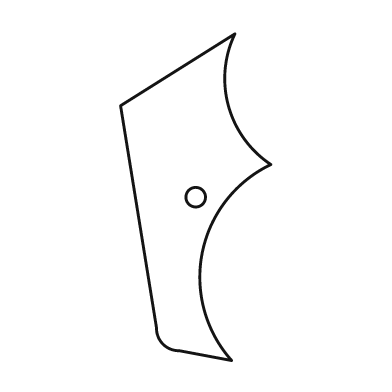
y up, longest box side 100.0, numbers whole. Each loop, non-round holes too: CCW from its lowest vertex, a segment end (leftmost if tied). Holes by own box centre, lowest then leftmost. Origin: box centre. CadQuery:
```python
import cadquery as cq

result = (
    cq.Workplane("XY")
    .moveTo(11.0, -50.0)
    .threePointArc((2.0, -17.0), (23.0, 10.0))
    .threePointArc((10.0, 28.0), (12.0, 50.0))
    .lineTo(-23.0, 28.0)
    .lineTo(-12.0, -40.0)
    .threePointArc((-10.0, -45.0), (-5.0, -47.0))
    .close()
    .moveTo(0.0, 0.0)
    .circle(3.0)
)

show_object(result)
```